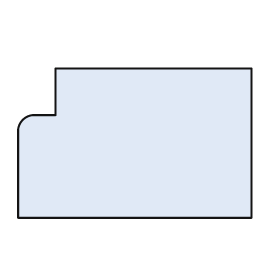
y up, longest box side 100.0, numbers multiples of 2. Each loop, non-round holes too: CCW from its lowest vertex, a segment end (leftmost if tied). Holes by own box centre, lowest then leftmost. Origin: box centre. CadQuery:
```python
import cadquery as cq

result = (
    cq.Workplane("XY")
    .moveTo(-50.0, -32.0)
    .lineTo(50.0, -32.0)
    .lineTo(50.0, 32.0)
    .lineTo(-34.0, 32.0)
    .lineTo(-34.0, 12.0)
    .lineTo(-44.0, 12.0)
    .threePointArc((-48.0, 10.0), (-50.0, 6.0))
    .close()
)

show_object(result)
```